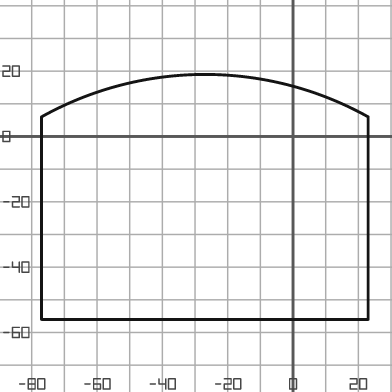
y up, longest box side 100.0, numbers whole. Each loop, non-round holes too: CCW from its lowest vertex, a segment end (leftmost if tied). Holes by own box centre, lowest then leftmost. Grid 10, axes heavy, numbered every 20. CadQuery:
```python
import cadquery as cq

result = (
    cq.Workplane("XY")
    .moveTo(-77.0, -56.0)
    .lineTo(23.0, -56.0)
    .lineTo(23.0, 6.0)
    .threePointArc((-27.0, 19.0), (-77.0, 6.0))
    .close()
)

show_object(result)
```